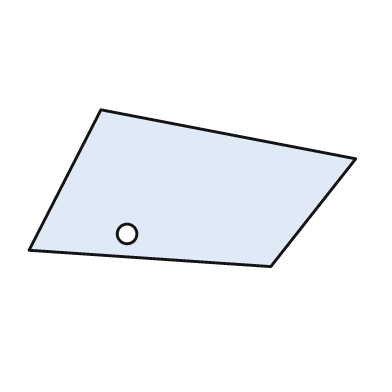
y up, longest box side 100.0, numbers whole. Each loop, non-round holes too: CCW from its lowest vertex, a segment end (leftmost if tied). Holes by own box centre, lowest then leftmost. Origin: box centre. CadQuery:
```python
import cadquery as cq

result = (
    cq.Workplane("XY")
    .moveTo(24.0, -24.0)
    .lineTo(50.0, 9.0)
    .lineTo(-28.0, 24.0)
    .lineTo(-50.0, -19.0)
    .close()
    .moveTo(-20.0, -14.0)
    .circle(3.0)
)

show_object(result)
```